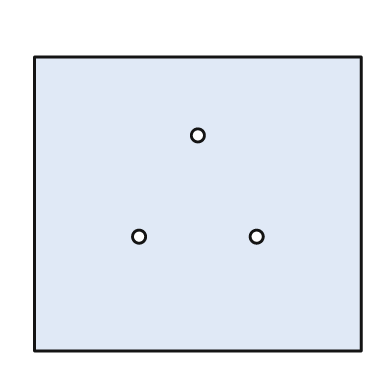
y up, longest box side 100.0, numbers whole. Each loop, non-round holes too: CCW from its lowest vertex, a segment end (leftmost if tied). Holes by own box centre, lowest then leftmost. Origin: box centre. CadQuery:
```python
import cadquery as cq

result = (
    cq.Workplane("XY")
    .moveTo(-50.0, -45.0)
    .lineTo(50.0, -45.0)
    .lineTo(50.0, 45.0)
    .lineTo(-50.0, 45.0)
    .close()
    .moveTo(-18.0, -10.0)
    .circle(2.0)
    .moveTo(18.0, -10.0)
    .circle(2.0)
    .moveTo(0.0, 21.0)
    .circle(2.0)
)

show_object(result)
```